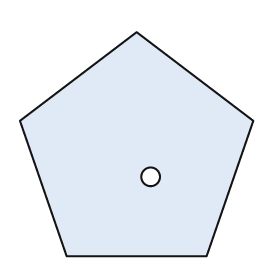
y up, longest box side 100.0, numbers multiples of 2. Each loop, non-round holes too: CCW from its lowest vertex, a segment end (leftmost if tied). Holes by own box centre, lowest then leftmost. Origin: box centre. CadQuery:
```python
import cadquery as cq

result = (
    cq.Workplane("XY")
    .moveTo(-30.0, -48.0)
    .lineTo(30.0, -48.0)
    .lineTo(50.0, 10.0)
    .lineTo(0.0, 48.0)
    .lineTo(-50.0, 10.0)
    .close()
    .moveTo(6.0, -14.0)
    .circle(4.0)
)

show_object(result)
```